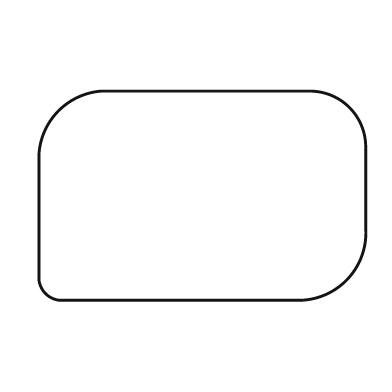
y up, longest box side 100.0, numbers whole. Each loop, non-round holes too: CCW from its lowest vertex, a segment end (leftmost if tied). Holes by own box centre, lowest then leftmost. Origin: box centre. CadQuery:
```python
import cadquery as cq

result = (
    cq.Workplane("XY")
    .moveTo(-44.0, -32.0)
    .lineTo(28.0, -32.0)
    .threePointArc((44.0, -26.0), (50.0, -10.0))
    .lineTo(50.0, 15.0)
    .threePointArc((45.0, 27.0), (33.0, 32.0))
    .lineTo(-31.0, 32.0)
    .threePointArc((-44.0, 26.0), (-50.0, 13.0))
    .lineTo(-50.0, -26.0)
    .threePointArc((-48.0, -30.0), (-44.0, -32.0))
    .close()
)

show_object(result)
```